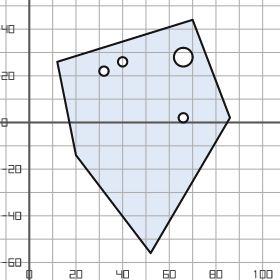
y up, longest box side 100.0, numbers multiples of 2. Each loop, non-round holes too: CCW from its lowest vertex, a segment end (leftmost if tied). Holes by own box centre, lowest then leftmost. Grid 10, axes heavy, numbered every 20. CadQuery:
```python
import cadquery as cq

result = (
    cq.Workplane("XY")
    .moveTo(52.0, -56.0)
    .lineTo(86.0, 2.0)
    .lineTo(70.0, 44.0)
    .lineTo(12.0, 26.0)
    .lineTo(20.0, -14.0)
    .close()
    .moveTo(66.0, 2.0)
    .circle(2.0)
    .moveTo(32.0, 22.0)
    .circle(2.0)
    .moveTo(40.0, 26.0)
    .circle(2.0)
    .moveTo(66.0, 28.0)
    .circle(4.0)
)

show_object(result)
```